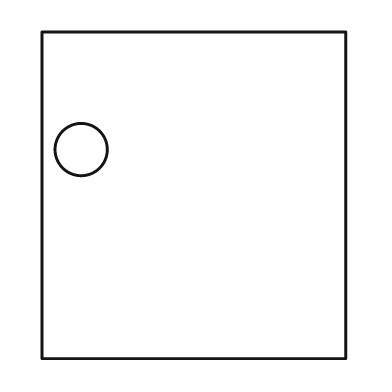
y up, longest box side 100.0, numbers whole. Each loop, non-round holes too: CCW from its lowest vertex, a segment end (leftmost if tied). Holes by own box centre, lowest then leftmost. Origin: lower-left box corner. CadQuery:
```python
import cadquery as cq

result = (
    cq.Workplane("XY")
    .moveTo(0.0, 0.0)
    .lineTo(93.0, 0.0)
    .lineTo(93.0, 100.0)
    .lineTo(0.0, 100.0)
    .close()
    .moveTo(12.0, 64.0)
    .circle(8.0)
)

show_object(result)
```